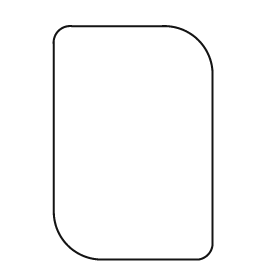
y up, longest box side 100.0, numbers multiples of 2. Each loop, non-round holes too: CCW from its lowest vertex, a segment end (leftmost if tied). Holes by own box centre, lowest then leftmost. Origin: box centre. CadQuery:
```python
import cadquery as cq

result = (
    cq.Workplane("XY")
    .moveTo(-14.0, -50.0)
    .lineTo(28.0, -50.0)
    .threePointArc((32.0, -48.0), (34.0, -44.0))
    .lineTo(34.0, 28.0)
    .threePointArc((28.0, 44.0), (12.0, 50.0))
    .lineTo(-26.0, 50.0)
    .threePointArc((-32.0, 48.0), (-34.0, 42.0))
    .lineTo(-34.0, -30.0)
    .threePointArc((-28.0, -44.0), (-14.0, -50.0))
    .close()
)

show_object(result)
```